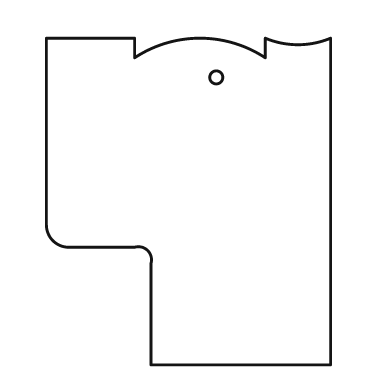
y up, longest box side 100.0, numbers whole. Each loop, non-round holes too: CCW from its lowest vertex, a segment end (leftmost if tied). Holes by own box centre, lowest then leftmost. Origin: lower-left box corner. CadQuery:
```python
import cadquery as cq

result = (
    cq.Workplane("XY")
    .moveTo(32.0, 0.0)
    .lineTo(87.0, 0.0)
    .lineTo(87.0, 100.0)
    .threePointArc((77.0, 98.0), (67.0, 100.0))
    .lineTo(67.0, 94.0)
    .threePointArc((47.0, 100.0), (27.0, 94.0))
    .lineTo(27.0, 100.0)
    .lineTo(0.0, 100.0)
    .lineTo(0.0, 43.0)
    .threePointArc((2.0, 38.0), (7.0, 36.0))
    .lineTo(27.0, 36.0)
    .threePointArc((31.0, 35.0), (32.0, 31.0))
    .close()
    .moveTo(52.0, 88.0)
    .circle(2.0)
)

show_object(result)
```